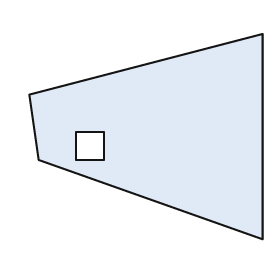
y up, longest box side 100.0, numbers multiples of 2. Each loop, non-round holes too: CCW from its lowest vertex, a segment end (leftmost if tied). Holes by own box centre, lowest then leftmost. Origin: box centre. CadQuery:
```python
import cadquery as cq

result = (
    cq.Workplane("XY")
    .moveTo(50.0, -44.0)
    .lineTo(50.0, 44.0)
    .lineTo(-50.0, 18.0)
    .lineTo(-46.0, -10.0)
    .close()
    .moveTo(-30.0, -10.0)
    .lineTo(-18.0, -10.0)
    .lineTo(-18.0, 2.0)
    .lineTo(-30.0, 2.0)
    .close()
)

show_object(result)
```